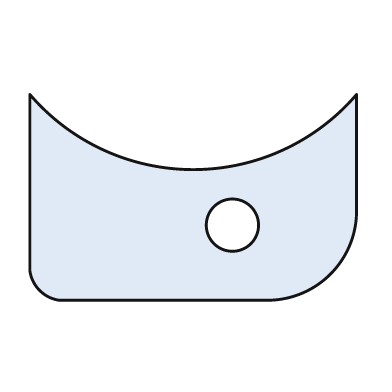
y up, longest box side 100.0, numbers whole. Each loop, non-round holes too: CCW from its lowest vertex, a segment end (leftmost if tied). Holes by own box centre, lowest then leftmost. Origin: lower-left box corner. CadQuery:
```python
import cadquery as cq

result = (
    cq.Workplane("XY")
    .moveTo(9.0, 0.0)
    .lineTo(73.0, 0.0)
    .threePointArc((92.0, 8.0), (100.0, 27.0))
    .lineTo(100.0, 63.0)
    .threePointArc((50.0, 40.0), (0.0, 63.0))
    .lineTo(0.0, 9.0)
    .threePointArc((3.0, 3.0), (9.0, 0.0))
    .close()
    .moveTo(62.0, 23.0)
    .circle(8.0)
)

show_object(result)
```